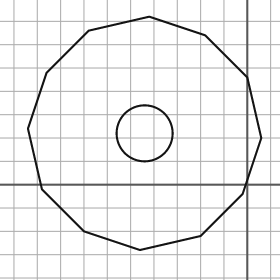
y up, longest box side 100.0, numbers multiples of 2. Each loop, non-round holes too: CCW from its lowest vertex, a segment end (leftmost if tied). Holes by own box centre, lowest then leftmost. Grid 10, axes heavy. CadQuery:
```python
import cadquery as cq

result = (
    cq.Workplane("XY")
    .moveTo(-46.0, -28.0)
    .lineTo(-20.0, -22.0)
    .lineTo(-2.0, -4.0)
    .lineTo(6.0, 20.0)
    .lineTo(0.0, 46.0)
    .lineTo(-18.0, 64.0)
    .lineTo(-42.0, 72.0)
    .lineTo(-68.0, 66.0)
    .lineTo(-86.0, 48.0)
    .lineTo(-94.0, 24.0)
    .lineTo(-88.0, -2.0)
    .lineTo(-70.0, -20.0)
    .close()
    .moveTo(-44.0, 22.0)
    .circle(12.0)
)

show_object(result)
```